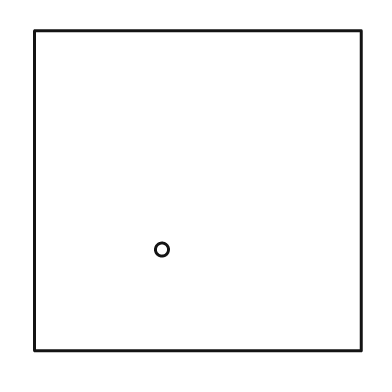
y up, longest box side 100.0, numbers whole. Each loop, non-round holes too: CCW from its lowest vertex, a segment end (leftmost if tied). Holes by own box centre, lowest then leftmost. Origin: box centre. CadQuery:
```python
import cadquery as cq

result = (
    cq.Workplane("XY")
    .moveTo(-50.0, -49.0)
    .lineTo(50.0, -49.0)
    .lineTo(50.0, 49.0)
    .lineTo(-50.0, 49.0)
    .close()
    .moveTo(-11.0, -18.0)
    .circle(2.0)
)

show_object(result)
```